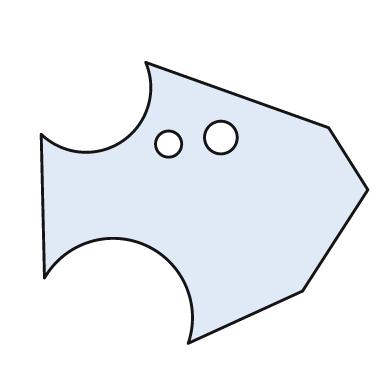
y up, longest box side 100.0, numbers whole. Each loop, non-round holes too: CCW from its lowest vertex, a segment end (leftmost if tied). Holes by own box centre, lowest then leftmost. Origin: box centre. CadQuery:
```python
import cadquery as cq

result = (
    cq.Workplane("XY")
    .moveTo(-5.0, -43.0)
    .lineTo(30.0, -27.0)
    .lineTo(50.0, 4.0)
    .lineTo(38.0, 23.0)
    .lineTo(-18.0, 43.0)
    .threePointArc((-25.0, 19.0), (-50.0, 21.0))
    .lineTo(-49.0, -23.0)
    .threePointArc((-18.0, -13.0), (-5.0, -43.0))
    .close()
    .moveTo(-11.0, 18.0)
    .circle(4.0)
    .moveTo(5.0, 20.0)
    .circle(5.0)
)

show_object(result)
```